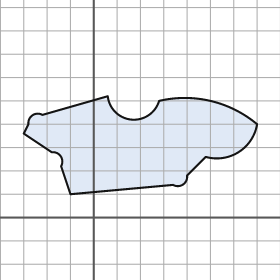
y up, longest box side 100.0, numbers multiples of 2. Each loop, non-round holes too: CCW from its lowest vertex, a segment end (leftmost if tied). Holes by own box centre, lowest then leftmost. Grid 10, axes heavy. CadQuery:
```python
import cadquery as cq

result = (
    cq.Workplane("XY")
    .moveTo(-10.0, 10.0)
    .lineTo(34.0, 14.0)
    .threePointArc((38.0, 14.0), (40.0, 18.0))
    .lineTo(48.0, 26.0)
    .threePointArc((62.0, 28.0), (70.0, 40.0))
    .threePointArc((50.0, 50.0), (28.0, 50.0))
    .threePointArc((16.0, 42.0), (6.0, 52.0))
    .lineTo(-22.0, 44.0)
    .threePointArc((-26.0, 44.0), (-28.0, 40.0))
    .lineTo(-30.0, 36.0)
    .lineTo(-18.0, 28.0)
    .threePointArc((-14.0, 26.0), (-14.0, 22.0))
    .close()
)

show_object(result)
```